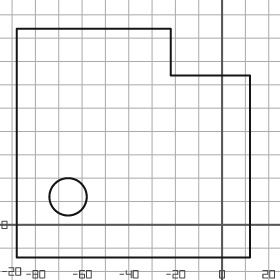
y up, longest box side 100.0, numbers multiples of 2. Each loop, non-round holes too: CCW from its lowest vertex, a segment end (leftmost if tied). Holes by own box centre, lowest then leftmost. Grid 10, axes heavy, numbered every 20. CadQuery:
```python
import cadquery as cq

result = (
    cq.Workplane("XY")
    .moveTo(-88.0, -14.0)
    .lineTo(12.0, -14.0)
    .lineTo(12.0, 64.0)
    .lineTo(-22.0, 64.0)
    .lineTo(-22.0, 84.0)
    .lineTo(-88.0, 84.0)
    .close()
    .moveTo(-66.0, 12.0)
    .circle(8.0)
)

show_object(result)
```